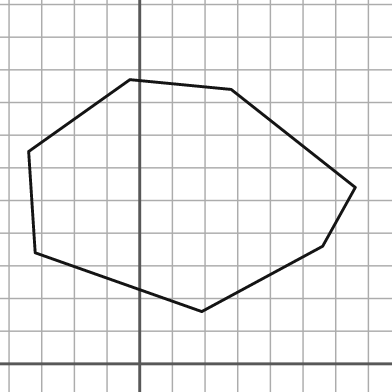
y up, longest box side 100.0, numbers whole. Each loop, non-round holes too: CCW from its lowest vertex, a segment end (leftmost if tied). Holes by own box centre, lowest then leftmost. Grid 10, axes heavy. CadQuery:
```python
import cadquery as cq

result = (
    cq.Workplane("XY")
    .moveTo(19.0, 16.0)
    .lineTo(56.0, 36.0)
    .lineTo(66.0, 54.0)
    .lineTo(28.0, 84.0)
    .lineTo(-3.0, 87.0)
    .lineTo(-34.0, 65.0)
    .lineTo(-32.0, 34.0)
    .close()
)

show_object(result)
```